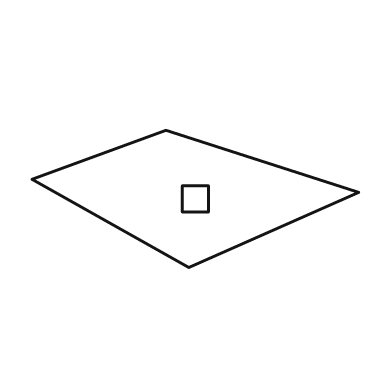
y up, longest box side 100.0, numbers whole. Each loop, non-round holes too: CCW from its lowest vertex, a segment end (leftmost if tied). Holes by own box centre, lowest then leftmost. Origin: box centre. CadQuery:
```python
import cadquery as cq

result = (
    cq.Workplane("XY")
    .moveTo(-2.0, -21.0)
    .lineTo(50.0, 2.0)
    .lineTo(-9.0, 21.0)
    .lineTo(-50.0, 6.0)
    .close()
    .moveTo(-4.0, -4.0)
    .lineTo(4.0, -4.0)
    .lineTo(4.0, 4.0)
    .lineTo(-4.0, 4.0)
    .close()
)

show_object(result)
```